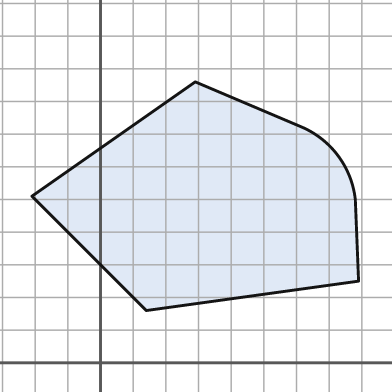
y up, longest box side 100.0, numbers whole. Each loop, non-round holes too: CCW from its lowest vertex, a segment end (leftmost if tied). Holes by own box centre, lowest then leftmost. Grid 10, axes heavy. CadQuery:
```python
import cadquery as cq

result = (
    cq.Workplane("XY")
    .moveTo(14.0, 16.0)
    .lineTo(79.0, 25.0)
    .lineTo(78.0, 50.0)
    .threePointArc((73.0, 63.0), (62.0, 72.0))
    .lineTo(29.0, 86.0)
    .lineTo(-21.0, 51.0)
    .close()
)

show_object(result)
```